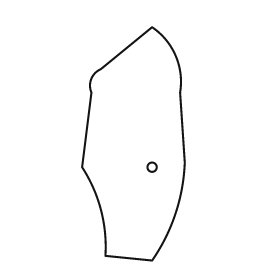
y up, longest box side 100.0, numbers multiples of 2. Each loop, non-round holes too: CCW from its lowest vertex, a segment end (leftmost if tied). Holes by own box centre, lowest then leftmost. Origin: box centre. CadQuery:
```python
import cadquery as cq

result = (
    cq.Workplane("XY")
    .moveTo(8.0, -50.0)
    .threePointArc((18.0, -30.0), (22.0, -8.0))
    .lineTo(20.0, 22.0)
    .threePointArc((18.0, 38.0), (8.0, 50.0))
    .lineTo(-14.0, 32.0)
    .threePointArc((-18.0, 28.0), (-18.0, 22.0))
    .lineTo(-22.0, -10.0)
    .threePointArc((-14.0, -28.0), (-12.0, -48.0))
    .close()
    .moveTo(8.0, -10.0)
    .circle(2.0)
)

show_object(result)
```